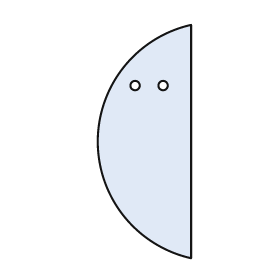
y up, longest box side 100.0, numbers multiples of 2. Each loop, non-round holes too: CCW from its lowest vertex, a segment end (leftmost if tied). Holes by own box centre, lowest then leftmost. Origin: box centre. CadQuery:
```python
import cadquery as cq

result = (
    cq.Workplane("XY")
    .moveTo(20.0, -50.0)
    .lineTo(20.0, 50.0)
    .threePointArc((-20.0, 0.0), (20.0, -50.0))
    .close()
    .moveTo(-4.0, 24.0)
    .circle(2.0)
    .moveTo(8.0, 24.0)
    .circle(2.0)
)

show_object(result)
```